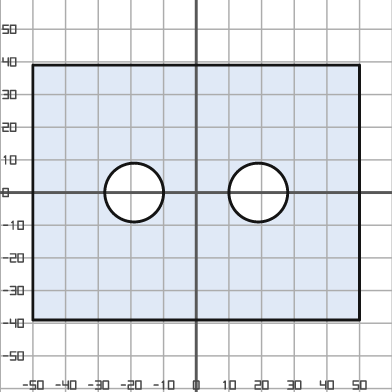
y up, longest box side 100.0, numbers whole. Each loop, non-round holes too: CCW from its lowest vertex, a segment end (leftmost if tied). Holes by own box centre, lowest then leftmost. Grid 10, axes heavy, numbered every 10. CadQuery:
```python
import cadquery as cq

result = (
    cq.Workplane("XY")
    .moveTo(-50.0, -39.0)
    .lineTo(50.0, -39.0)
    .lineTo(50.0, 39.0)
    .lineTo(-50.0, 39.0)
    .close()
    .moveTo(-19.0, 0.0)
    .circle(9.0)
    .moveTo(19.0, 0.0)
    .circle(9.0)
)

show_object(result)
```